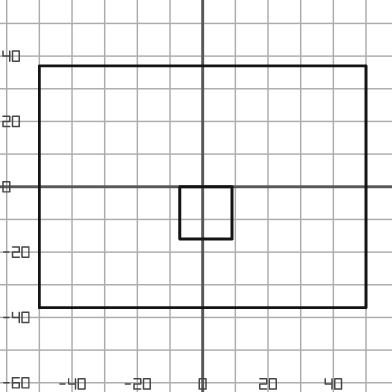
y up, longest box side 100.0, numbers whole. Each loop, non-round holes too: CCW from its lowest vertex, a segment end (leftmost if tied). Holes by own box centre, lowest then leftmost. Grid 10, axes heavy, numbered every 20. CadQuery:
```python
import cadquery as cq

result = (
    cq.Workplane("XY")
    .moveTo(-50.0, -37.0)
    .lineTo(50.0, -37.0)
    .lineTo(50.0, 37.0)
    .lineTo(-50.0, 37.0)
    .close()
    .moveTo(-7.0, -16.0)
    .lineTo(9.0, -16.0)
    .lineTo(9.0, 0.0)
    .lineTo(-7.0, 0.0)
    .close()
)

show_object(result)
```